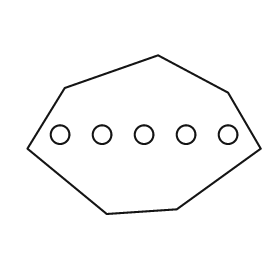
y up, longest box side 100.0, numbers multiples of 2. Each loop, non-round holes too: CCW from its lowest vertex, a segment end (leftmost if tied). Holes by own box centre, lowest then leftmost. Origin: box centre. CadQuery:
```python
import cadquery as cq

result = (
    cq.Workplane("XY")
    .moveTo(-16.0, -34.0)
    .lineTo(14.0, -32.0)
    .lineTo(50.0, -6.0)
    .lineTo(36.0, 18.0)
    .lineTo(6.0, 34.0)
    .lineTo(-34.0, 20.0)
    .lineTo(-50.0, -6.0)
    .close()
    .moveTo(-36.0, 0.0)
    .circle(4.0)
    .moveTo(-18.0, 0.0)
    .circle(4.0)
    .moveTo(0.0, 0.0)
    .circle(4.0)
    .moveTo(18.0, 0.0)
    .circle(4.0)
    .moveTo(36.0, 0.0)
    .circle(4.0)
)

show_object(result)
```